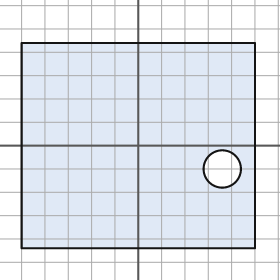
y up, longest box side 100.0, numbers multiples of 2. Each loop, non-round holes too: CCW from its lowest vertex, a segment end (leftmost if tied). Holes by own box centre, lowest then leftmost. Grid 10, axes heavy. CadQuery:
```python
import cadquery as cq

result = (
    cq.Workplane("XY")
    .moveTo(-50.0, -44.0)
    .lineTo(50.0, -44.0)
    .lineTo(50.0, 44.0)
    .lineTo(-50.0, 44.0)
    .close()
    .moveTo(36.0, -10.0)
    .circle(8.0)
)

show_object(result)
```